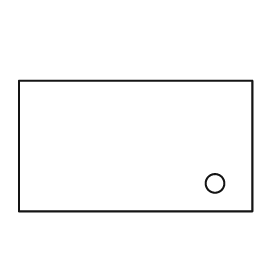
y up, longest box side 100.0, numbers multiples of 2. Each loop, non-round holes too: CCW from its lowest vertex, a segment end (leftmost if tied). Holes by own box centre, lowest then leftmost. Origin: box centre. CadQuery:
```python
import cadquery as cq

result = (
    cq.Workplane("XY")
    .moveTo(-50.0, -28.0)
    .lineTo(50.0, -28.0)
    .lineTo(50.0, 28.0)
    .lineTo(-50.0, 28.0)
    .close()
    .moveTo(34.0, -16.0)
    .circle(4.0)
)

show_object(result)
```